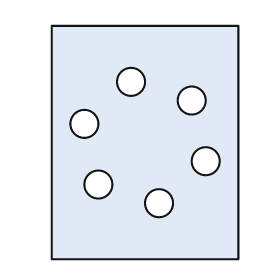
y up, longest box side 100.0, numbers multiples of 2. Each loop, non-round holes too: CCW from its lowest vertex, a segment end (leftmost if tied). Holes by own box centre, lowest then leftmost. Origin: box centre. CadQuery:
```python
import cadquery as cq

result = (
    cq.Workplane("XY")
    .moveTo(-40.0, -50.0)
    .lineTo(40.0, -50.0)
    .lineTo(40.0, 50.0)
    .lineTo(-40.0, 50.0)
    .close()
    .moveTo(6.0, -26.0)
    .circle(6.0)
    .moveTo(-20.0, -18.0)
    .circle(6.0)
    .moveTo(26.0, -8.0)
    .circle(6.0)
    .moveTo(-26.0, 8.0)
    .circle(6.0)
    .moveTo(20.0, 18.0)
    .circle(6.0)
    .moveTo(-6.0, 26.0)
    .circle(6.0)
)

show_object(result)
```